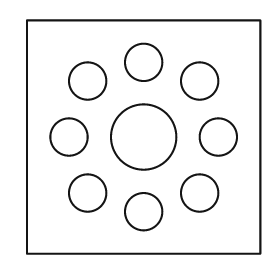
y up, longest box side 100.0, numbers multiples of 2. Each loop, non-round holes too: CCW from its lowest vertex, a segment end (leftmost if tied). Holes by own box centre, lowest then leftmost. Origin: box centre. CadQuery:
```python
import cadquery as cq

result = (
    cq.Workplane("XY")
    .moveTo(-50.0, -50.0)
    .lineTo(50.0, -50.0)
    .lineTo(50.0, 50.0)
    .lineTo(-50.0, 50.0)
    .close()
    .moveTo(0.0, -32.0)
    .circle(8.0)
    .moveTo(-24.0, -24.0)
    .circle(8.0)
    .moveTo(24.0, -24.0)
    .circle(8.0)
    .moveTo(-32.0, 0.0)
    .circle(8.0)
    .moveTo(0.0, 0.0)
    .circle(14.0)
    .moveTo(32.0, 0.0)
    .circle(8.0)
    .moveTo(-24.0, 24.0)
    .circle(8.0)
    .moveTo(24.0, 24.0)
    .circle(8.0)
    .moveTo(0.0, 32.0)
    .circle(8.0)
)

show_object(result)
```